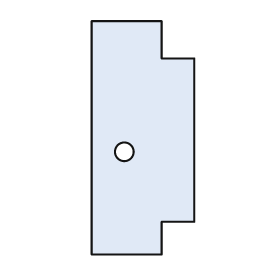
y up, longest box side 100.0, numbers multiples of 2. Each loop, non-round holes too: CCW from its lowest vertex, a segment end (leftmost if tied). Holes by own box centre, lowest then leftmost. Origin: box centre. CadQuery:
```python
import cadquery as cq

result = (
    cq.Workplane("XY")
    .moveTo(-22.0, -50.0)
    .lineTo(8.0, -50.0)
    .lineTo(8.0, -36.0)
    .lineTo(22.0, -36.0)
    .lineTo(22.0, 34.0)
    .lineTo(8.0, 34.0)
    .lineTo(8.0, 50.0)
    .lineTo(-22.0, 50.0)
    .close()
    .moveTo(-8.0, -6.0)
    .circle(4.0)
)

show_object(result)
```